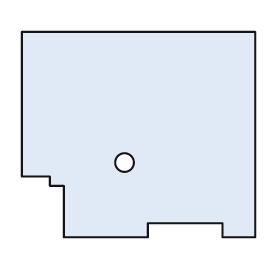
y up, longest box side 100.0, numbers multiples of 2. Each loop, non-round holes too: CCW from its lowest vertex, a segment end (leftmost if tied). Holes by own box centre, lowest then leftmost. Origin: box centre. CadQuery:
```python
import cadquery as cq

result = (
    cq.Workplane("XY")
    .moveTo(-32.0, -44.0)
    .lineTo(4.0, -44.0)
    .lineTo(4.0, -38.0)
    .lineTo(36.0, -38.0)
    .lineTo(36.0, -44.0)
    .lineTo(50.0, -44.0)
    .lineTo(50.0, 44.0)
    .lineTo(-50.0, 44.0)
    .lineTo(-50.0, -18.0)
    .lineTo(-38.0, -18.0)
    .lineTo(-38.0, -22.0)
    .lineTo(-32.0, -22.0)
    .close()
    .moveTo(-6.0, -12.0)
    .circle(4.0)
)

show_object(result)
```